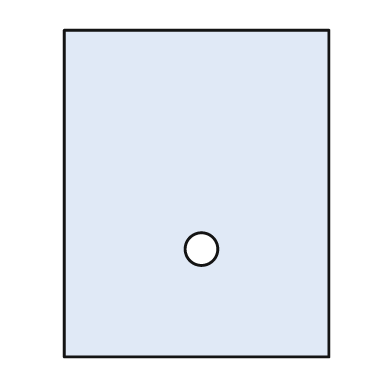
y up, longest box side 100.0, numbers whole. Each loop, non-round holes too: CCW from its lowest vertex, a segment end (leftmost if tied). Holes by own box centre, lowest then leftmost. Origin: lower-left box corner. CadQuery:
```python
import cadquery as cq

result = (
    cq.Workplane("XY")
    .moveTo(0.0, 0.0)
    .lineTo(81.0, 0.0)
    .lineTo(81.0, 100.0)
    .lineTo(0.0, 100.0)
    .close()
    .moveTo(42.0, 33.0)
    .circle(5.0)
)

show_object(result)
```